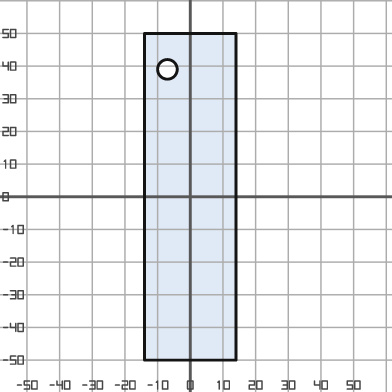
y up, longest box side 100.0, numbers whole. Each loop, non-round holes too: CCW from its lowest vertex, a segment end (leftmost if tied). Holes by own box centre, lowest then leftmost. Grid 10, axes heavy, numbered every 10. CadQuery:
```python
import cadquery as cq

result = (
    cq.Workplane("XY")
    .moveTo(-14.0, -50.0)
    .lineTo(14.0, -50.0)
    .lineTo(14.0, 50.0)
    .lineTo(-14.0, 50.0)
    .close()
    .moveTo(-7.0, 39.0)
    .circle(3.0)
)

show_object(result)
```